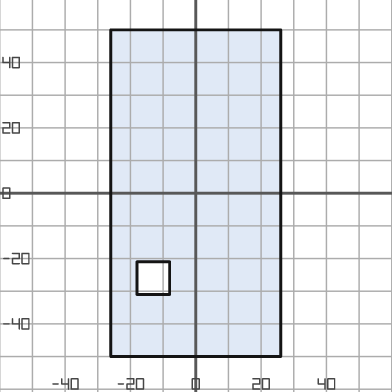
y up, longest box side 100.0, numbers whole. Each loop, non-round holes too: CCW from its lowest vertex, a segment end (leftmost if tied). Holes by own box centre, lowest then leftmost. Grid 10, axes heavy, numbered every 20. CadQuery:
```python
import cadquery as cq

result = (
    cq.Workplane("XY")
    .moveTo(-26.0, -50.0)
    .lineTo(26.0, -50.0)
    .lineTo(26.0, 50.0)
    .lineTo(-26.0, 50.0)
    .close()
    .moveTo(-18.0, -31.0)
    .lineTo(-8.0, -31.0)
    .lineTo(-8.0, -21.0)
    .lineTo(-18.0, -21.0)
    .close()
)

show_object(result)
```